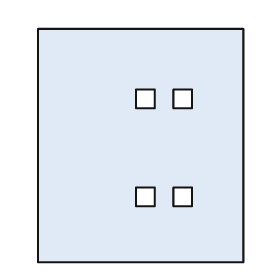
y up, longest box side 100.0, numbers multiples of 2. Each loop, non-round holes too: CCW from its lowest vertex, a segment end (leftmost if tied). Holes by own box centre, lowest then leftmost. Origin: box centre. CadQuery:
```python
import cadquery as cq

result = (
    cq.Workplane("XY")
    .moveTo(-44.0, -50.0)
    .lineTo(44.0, -50.0)
    .lineTo(44.0, 50.0)
    .lineTo(-44.0, 50.0)
    .close()
    .moveTo(-2.0, -26.0)
    .lineTo(6.0, -26.0)
    .lineTo(6.0, -18.0)
    .lineTo(-2.0, -18.0)
    .close()
    .moveTo(14.0, -26.0)
    .lineTo(22.0, -26.0)
    .lineTo(22.0, -18.0)
    .lineTo(14.0, -18.0)
    .close()
    .moveTo(-2.0, 16.0)
    .lineTo(6.0, 16.0)
    .lineTo(6.0, 24.0)
    .lineTo(-2.0, 24.0)
    .close()
    .moveTo(14.0, 16.0)
    .lineTo(22.0, 16.0)
    .lineTo(22.0, 24.0)
    .lineTo(14.0, 24.0)
    .close()
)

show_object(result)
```